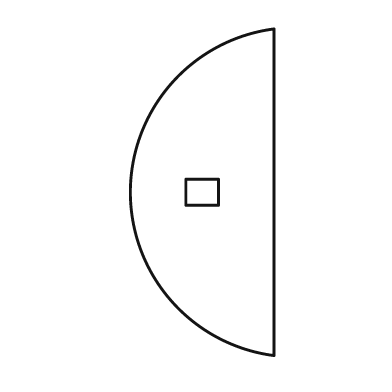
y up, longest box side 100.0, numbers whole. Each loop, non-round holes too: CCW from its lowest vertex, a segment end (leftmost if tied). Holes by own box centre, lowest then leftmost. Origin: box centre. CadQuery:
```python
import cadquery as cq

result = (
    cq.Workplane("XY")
    .moveTo(22.0, -50.0)
    .lineTo(22.0, 50.0)
    .threePointArc((-22.0, 0.0), (22.0, -50.0))
    .close()
    .moveTo(-5.0, -4.0)
    .lineTo(5.0, -4.0)
    .lineTo(5.0, 4.0)
    .lineTo(-5.0, 4.0)
    .close()
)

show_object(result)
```